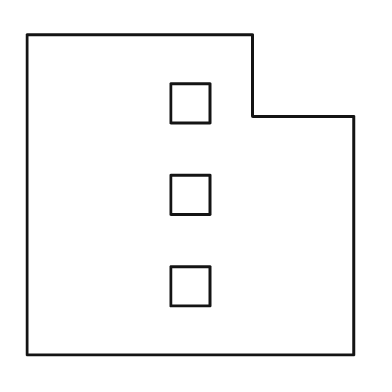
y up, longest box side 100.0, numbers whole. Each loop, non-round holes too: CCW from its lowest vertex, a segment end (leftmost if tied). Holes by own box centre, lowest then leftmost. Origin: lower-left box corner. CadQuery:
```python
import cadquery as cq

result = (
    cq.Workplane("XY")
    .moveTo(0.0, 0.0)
    .lineTo(100.0, 0.0)
    .lineTo(100.0, 73.0)
    .lineTo(69.0, 73.0)
    .lineTo(69.0, 98.0)
    .lineTo(0.0, 98.0)
    .close()
    .moveTo(44.0, 15.0)
    .lineTo(56.0, 15.0)
    .lineTo(56.0, 27.0)
    .lineTo(44.0, 27.0)
    .close()
    .moveTo(44.0, 43.0)
    .lineTo(56.0, 43.0)
    .lineTo(56.0, 55.0)
    .lineTo(44.0, 55.0)
    .close()
    .moveTo(44.0, 71.0)
    .lineTo(56.0, 71.0)
    .lineTo(56.0, 83.0)
    .lineTo(44.0, 83.0)
    .close()
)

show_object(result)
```